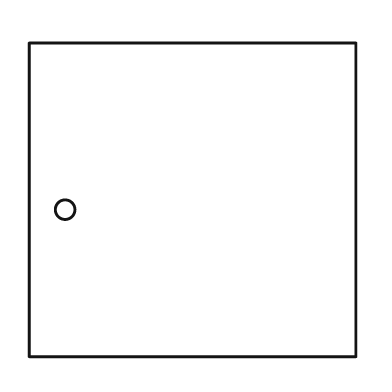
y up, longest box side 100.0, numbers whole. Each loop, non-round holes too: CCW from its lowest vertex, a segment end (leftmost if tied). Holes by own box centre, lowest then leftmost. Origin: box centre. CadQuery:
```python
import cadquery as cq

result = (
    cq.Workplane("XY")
    .moveTo(-50.0, -48.0)
    .lineTo(50.0, -48.0)
    .lineTo(50.0, 48.0)
    .lineTo(-50.0, 48.0)
    .close()
    .moveTo(-39.0, -3.0)
    .circle(3.0)
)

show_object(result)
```